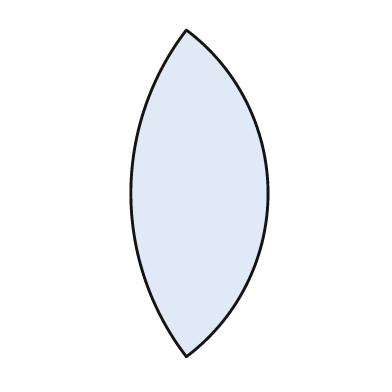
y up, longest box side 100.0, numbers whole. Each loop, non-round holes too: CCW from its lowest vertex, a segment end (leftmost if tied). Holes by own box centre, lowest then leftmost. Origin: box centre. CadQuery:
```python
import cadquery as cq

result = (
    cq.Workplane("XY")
    .moveTo(-4.0, -50.0)
    .threePointArc((21.0, 0.0), (-4.0, 50.0))
    .threePointArc((-21.0, 0.0), (-4.0, -50.0))
    .close()
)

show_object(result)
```